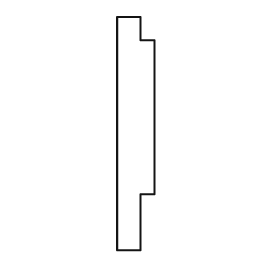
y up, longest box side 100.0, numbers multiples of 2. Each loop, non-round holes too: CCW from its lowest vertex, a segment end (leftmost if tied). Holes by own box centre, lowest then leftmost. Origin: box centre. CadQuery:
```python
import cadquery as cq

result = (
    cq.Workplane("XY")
    .moveTo(-8.0, -50.0)
    .lineTo(2.0, -50.0)
    .lineTo(2.0, -26.0)
    .lineTo(8.0, -26.0)
    .lineTo(8.0, 40.0)
    .lineTo(2.0, 40.0)
    .lineTo(2.0, 50.0)
    .lineTo(-8.0, 50.0)
    .close()
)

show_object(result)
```